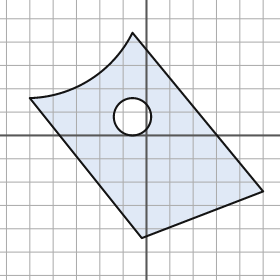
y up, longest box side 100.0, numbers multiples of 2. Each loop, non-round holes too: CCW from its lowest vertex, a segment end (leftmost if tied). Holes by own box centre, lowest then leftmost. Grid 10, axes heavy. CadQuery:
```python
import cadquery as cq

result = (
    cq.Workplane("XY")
    .moveTo(-2.0, -44.0)
    .lineTo(50.0, -24.0)
    .lineTo(-6.0, 44.0)
    .threePointArc((-24.0, 24.0), (-50.0, 16.0))
    .close()
    .moveTo(-6.0, 8.0)
    .circle(8.0)
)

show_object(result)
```